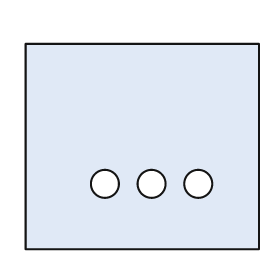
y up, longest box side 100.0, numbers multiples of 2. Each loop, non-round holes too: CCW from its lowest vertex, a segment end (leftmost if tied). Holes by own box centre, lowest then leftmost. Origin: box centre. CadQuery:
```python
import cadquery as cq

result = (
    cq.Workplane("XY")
    .moveTo(-50.0, -44.0)
    .lineTo(50.0, -44.0)
    .lineTo(50.0, 44.0)
    .lineTo(-50.0, 44.0)
    .close()
    .moveTo(-16.0, -16.0)
    .circle(6.0)
    .moveTo(4.0, -16.0)
    .circle(6.0)
    .moveTo(24.0, -16.0)
    .circle(6.0)
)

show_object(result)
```